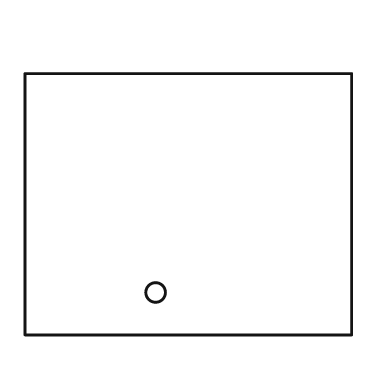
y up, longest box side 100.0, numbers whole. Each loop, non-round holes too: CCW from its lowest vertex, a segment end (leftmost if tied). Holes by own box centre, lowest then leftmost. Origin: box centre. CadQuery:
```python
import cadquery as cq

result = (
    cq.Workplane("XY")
    .moveTo(-50.0, -40.0)
    .lineTo(50.0, -40.0)
    .lineTo(50.0, 40.0)
    .lineTo(-50.0, 40.0)
    .close()
    .moveTo(-10.0, -27.0)
    .circle(3.0)
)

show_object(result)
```